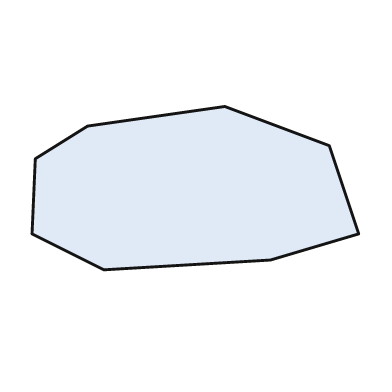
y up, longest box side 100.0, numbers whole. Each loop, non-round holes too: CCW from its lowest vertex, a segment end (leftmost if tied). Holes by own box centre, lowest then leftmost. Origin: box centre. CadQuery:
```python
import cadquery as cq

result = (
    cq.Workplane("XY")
    .moveTo(-28.0, -25.0)
    .lineTo(23.0, -22.0)
    .lineTo(50.0, -14.0)
    .lineTo(41.0, 13.0)
    .lineTo(9.0, 25.0)
    .lineTo(-33.0, 19.0)
    .lineTo(-49.0, 9.0)
    .lineTo(-50.0, -14.0)
    .close()
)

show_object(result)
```